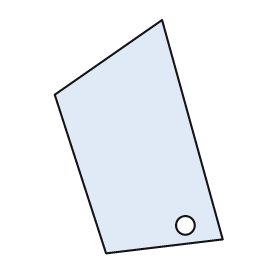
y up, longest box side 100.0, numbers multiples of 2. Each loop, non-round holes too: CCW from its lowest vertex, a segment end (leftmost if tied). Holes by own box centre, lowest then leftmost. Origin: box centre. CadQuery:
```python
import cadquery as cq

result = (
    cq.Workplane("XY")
    .moveTo(-14.0, -50.0)
    .lineTo(36.0, -44.0)
    .lineTo(10.0, 50.0)
    .lineTo(-36.0, 18.0)
    .close()
    .moveTo(20.0, -38.0)
    .circle(4.0)
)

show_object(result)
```